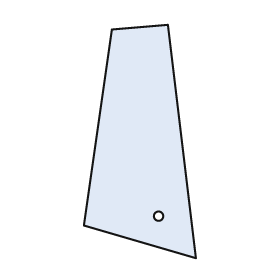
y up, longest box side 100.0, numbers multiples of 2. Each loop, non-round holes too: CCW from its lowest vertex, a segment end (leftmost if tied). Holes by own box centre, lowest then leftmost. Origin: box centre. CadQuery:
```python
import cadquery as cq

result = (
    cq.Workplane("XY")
    .moveTo(24.0, -50.0)
    .lineTo(12.0, 50.0)
    .lineTo(-12.0, 48.0)
    .lineTo(-24.0, -36.0)
    .close()
    .moveTo(8.0, -32.0)
    .circle(2.0)
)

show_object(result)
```